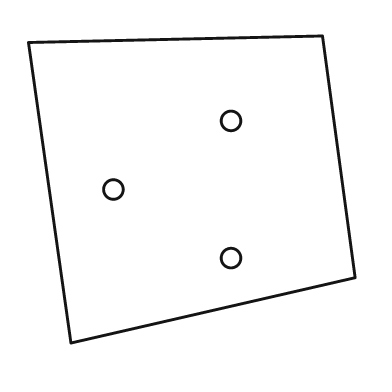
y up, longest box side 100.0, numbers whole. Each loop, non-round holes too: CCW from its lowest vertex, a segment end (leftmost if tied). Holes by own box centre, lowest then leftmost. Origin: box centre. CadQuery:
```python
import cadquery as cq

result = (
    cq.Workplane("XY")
    .moveTo(-37.0, -47.0)
    .lineTo(50.0, -27.0)
    .lineTo(40.0, 47.0)
    .lineTo(-50.0, 45.0)
    .close()
    .moveTo(12.0, -21.0)
    .circle(3.0)
    .moveTo(-24.0, 0.0)
    .circle(3.0)
    .moveTo(12.0, 21.0)
    .circle(3.0)
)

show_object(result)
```